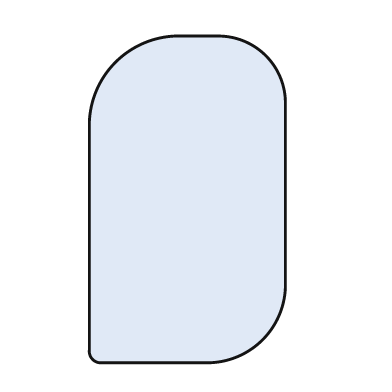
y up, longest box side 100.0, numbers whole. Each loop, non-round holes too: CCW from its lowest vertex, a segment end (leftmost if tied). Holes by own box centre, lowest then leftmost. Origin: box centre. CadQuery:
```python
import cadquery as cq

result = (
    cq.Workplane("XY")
    .moveTo(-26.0, -50.0)
    .lineTo(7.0, -50.0)
    .threePointArc((23.0, -43.0), (30.0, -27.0))
    .lineTo(30.0, 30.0)
    .threePointArc((24.0, 44.0), (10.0, 50.0))
    .lineTo(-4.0, 50.0)
    .threePointArc((-22.0, 42.0), (-30.0, 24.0))
    .lineTo(-30.0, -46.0)
    .threePointArc((-29.0, -49.0), (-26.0, -50.0))
    .close()
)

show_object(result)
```